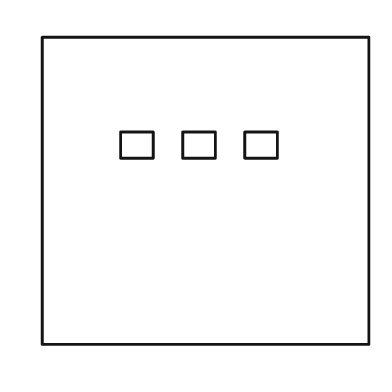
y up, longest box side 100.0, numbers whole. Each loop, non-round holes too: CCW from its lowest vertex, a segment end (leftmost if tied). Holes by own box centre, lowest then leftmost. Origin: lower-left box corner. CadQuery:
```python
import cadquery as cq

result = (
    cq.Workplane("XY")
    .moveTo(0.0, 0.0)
    .lineTo(100.0, 0.0)
    .lineTo(100.0, 94.0)
    .lineTo(0.0, 94.0)
    .close()
    .moveTo(24.0, 57.0)
    .lineTo(34.0, 57.0)
    .lineTo(34.0, 65.0)
    .lineTo(24.0, 65.0)
    .close()
    .moveTo(43.0, 57.0)
    .lineTo(53.0, 57.0)
    .lineTo(53.0, 65.0)
    .lineTo(43.0, 65.0)
    .close()
    .moveTo(62.0, 57.0)
    .lineTo(72.0, 57.0)
    .lineTo(72.0, 65.0)
    .lineTo(62.0, 65.0)
    .close()
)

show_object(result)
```